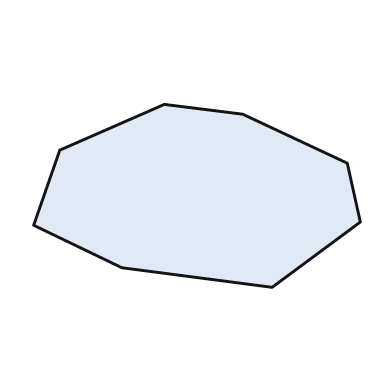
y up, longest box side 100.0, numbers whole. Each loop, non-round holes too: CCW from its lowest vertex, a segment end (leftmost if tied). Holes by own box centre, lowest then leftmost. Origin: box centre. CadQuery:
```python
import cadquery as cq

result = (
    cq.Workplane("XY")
    .moveTo(23.0, -28.0)
    .lineTo(50.0, -8.0)
    .lineTo(46.0, 10.0)
    .lineTo(14.0, 25.0)
    .lineTo(-10.0, 28.0)
    .lineTo(-42.0, 14.0)
    .lineTo(-50.0, -9.0)
    .lineTo(-23.0, -22.0)
    .close()
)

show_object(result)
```